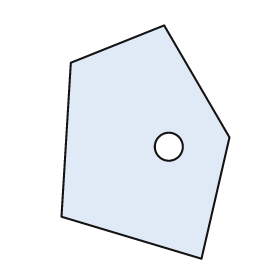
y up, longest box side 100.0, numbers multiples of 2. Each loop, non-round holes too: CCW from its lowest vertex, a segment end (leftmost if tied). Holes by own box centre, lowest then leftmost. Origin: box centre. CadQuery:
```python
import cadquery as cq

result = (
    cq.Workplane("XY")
    .moveTo(24.0, -50.0)
    .lineTo(36.0, 2.0)
    .lineTo(8.0, 50.0)
    .lineTo(-32.0, 34.0)
    .lineTo(-36.0, -32.0)
    .close()
    .moveTo(10.0, -2.0)
    .circle(6.0)
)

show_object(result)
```